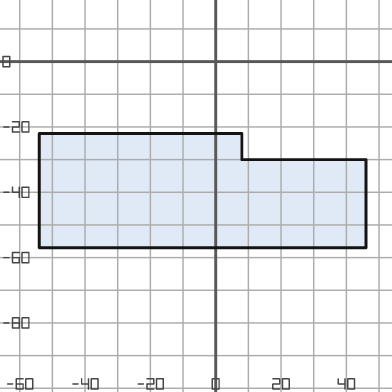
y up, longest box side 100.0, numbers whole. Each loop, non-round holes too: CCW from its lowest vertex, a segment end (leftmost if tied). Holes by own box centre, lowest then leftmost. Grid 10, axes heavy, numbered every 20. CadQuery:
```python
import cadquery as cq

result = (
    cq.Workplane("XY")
    .moveTo(-54.0, -57.0)
    .lineTo(46.0, -57.0)
    .lineTo(46.0, -30.0)
    .lineTo(8.0, -30.0)
    .lineTo(8.0, -22.0)
    .lineTo(-54.0, -22.0)
    .close()
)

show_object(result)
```